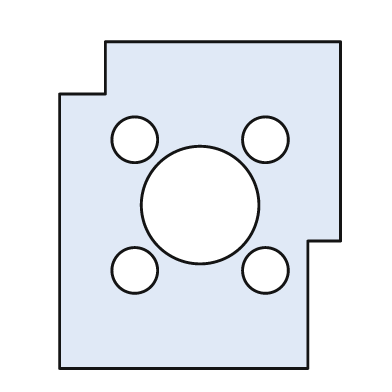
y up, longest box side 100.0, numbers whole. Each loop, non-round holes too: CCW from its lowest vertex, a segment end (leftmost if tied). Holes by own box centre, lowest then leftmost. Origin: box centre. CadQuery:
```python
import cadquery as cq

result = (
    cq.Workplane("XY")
    .moveTo(-43.0, -50.0)
    .lineTo(33.0, -50.0)
    .lineTo(33.0, -11.0)
    .lineTo(43.0, -11.0)
    .lineTo(43.0, 50.0)
    .lineTo(-29.0, 50.0)
    .lineTo(-29.0, 34.0)
    .lineTo(-43.0, 34.0)
    .close()
    .moveTo(-20.0, -20.0)
    .circle(7.0)
    .moveTo(20.0, -20.0)
    .circle(7.0)
    .moveTo(0.0, 0.0)
    .circle(18.0)
    .moveTo(-20.0, 20.0)
    .circle(7.0)
    .moveTo(20.0, 20.0)
    .circle(7.0)
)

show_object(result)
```